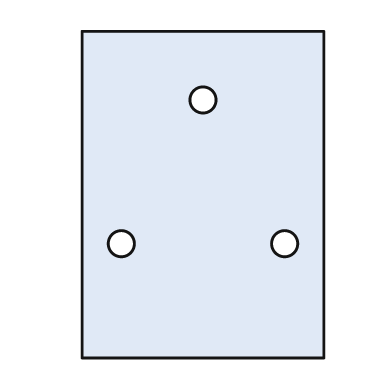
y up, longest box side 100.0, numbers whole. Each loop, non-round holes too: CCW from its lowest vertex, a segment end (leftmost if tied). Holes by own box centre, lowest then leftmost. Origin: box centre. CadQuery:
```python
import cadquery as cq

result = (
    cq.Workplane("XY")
    .moveTo(-37.0, -50.0)
    .lineTo(37.0, -50.0)
    .lineTo(37.0, 50.0)
    .lineTo(-37.0, 50.0)
    .close()
    .moveTo(-25.0, -15.0)
    .circle(4.0)
    .moveTo(25.0, -15.0)
    .circle(4.0)
    .moveTo(0.0, 29.0)
    .circle(4.0)
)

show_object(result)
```